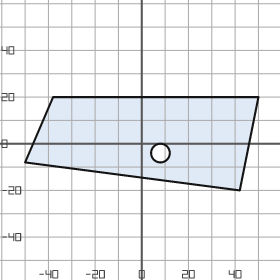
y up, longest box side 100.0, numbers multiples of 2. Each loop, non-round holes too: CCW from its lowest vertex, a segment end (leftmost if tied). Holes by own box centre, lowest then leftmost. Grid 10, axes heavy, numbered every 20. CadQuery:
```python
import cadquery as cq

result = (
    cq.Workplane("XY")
    .moveTo(42.0, -20.0)
    .lineTo(50.0, 20.0)
    .lineTo(-38.0, 20.0)
    .lineTo(-50.0, -8.0)
    .close()
    .moveTo(8.0, -4.0)
    .circle(4.0)
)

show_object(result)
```